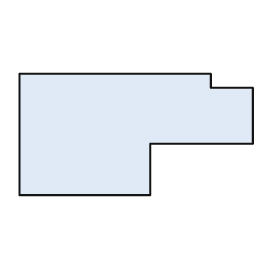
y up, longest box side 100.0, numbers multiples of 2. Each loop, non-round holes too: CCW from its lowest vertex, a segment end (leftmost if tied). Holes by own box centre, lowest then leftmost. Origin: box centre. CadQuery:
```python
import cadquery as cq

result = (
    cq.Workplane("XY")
    .moveTo(-50.0, -26.0)
    .lineTo(6.0, -26.0)
    .lineTo(6.0, -4.0)
    .lineTo(50.0, -4.0)
    .lineTo(50.0, 20.0)
    .lineTo(32.0, 20.0)
    .lineTo(32.0, 26.0)
    .lineTo(-50.0, 26.0)
    .close()
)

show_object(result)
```